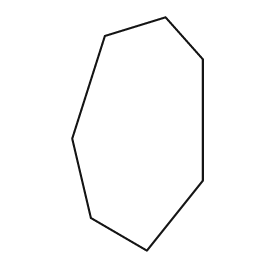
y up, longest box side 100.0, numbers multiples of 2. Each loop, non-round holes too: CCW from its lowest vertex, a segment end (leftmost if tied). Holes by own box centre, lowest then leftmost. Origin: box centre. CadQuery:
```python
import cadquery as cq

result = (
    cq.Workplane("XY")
    .moveTo(4.0, -50.0)
    .lineTo(28.0, -20.0)
    .lineTo(28.0, 32.0)
    .lineTo(12.0, 50.0)
    .lineTo(-14.0, 42.0)
    .lineTo(-28.0, -2.0)
    .lineTo(-20.0, -36.0)
    .close()
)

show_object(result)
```